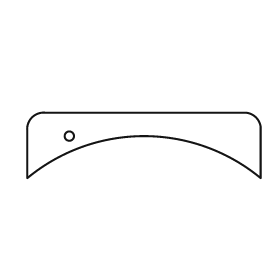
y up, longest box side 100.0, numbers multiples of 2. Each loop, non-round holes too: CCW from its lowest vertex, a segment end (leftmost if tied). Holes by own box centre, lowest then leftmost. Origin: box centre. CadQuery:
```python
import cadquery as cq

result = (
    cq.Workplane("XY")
    .moveTo(-50.0, -14.0)
    .threePointArc((0.0, 4.0), (50.0, -14.0))
    .lineTo(50.0, 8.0)
    .threePointArc((48.0, 12.0), (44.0, 14.0))
    .lineTo(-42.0, 14.0)
    .threePointArc((-48.0, 12.0), (-50.0, 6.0))
    .close()
    .moveTo(-32.0, 4.0)
    .circle(2.0)
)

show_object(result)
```